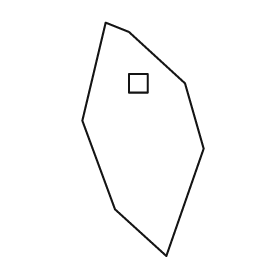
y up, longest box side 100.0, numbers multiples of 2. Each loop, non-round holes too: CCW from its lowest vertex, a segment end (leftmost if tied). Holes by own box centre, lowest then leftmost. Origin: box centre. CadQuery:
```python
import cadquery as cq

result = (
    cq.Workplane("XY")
    .moveTo(10.0, -50.0)
    .lineTo(26.0, -4.0)
    .lineTo(18.0, 24.0)
    .lineTo(-6.0, 46.0)
    .lineTo(-16.0, 50.0)
    .lineTo(-26.0, 8.0)
    .lineTo(-12.0, -30.0)
    .close()
    .moveTo(-6.0, 20.0)
    .lineTo(2.0, 20.0)
    .lineTo(2.0, 28.0)
    .lineTo(-6.0, 28.0)
    .close()
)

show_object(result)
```